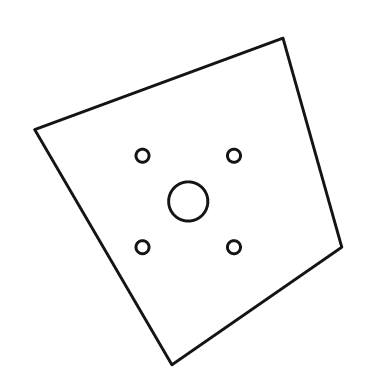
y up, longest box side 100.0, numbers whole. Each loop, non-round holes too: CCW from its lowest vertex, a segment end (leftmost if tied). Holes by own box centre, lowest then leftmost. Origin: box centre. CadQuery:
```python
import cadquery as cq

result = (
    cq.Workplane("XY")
    .moveTo(-5.0, -50.0)
    .lineTo(47.0, -14.0)
    .lineTo(29.0, 50.0)
    .lineTo(-47.0, 22.0)
    .close()
    .moveTo(-14.0, -14.0)
    .circle(2.0)
    .moveTo(14.0, -14.0)
    .circle(2.0)
    .moveTo(0.0, 0.0)
    .circle(6.0)
    .moveTo(-14.0, 14.0)
    .circle(2.0)
    .moveTo(14.0, 14.0)
    .circle(2.0)
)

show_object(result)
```